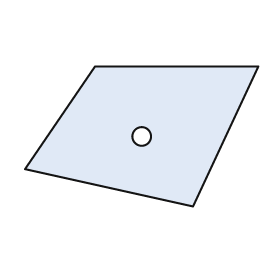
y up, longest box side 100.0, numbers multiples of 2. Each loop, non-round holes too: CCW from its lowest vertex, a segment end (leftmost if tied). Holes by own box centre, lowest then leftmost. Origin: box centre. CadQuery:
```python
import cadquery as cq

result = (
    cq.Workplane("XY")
    .moveTo(22.0, -30.0)
    .lineTo(50.0, 30.0)
    .lineTo(-20.0, 30.0)
    .lineTo(-50.0, -14.0)
    .close()
    .moveTo(0.0, 0.0)
    .circle(4.0)
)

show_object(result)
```